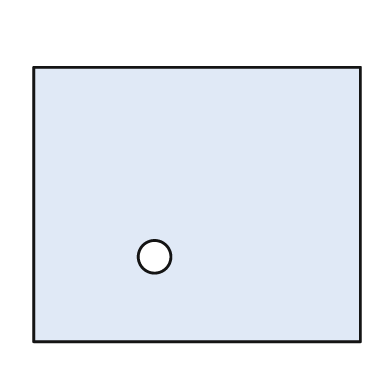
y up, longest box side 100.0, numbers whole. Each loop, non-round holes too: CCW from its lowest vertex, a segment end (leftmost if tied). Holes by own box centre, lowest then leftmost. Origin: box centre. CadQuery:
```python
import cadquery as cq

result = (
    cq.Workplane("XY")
    .moveTo(-50.0, -42.0)
    .lineTo(50.0, -42.0)
    .lineTo(50.0, 42.0)
    .lineTo(-50.0, 42.0)
    .close()
    .moveTo(-13.0, -16.0)
    .circle(5.0)
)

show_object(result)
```